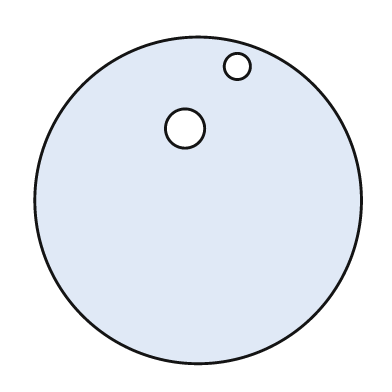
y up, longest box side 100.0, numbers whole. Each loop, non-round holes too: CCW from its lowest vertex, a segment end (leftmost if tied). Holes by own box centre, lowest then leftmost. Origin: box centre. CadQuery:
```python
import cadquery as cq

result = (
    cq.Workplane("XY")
    .moveTo(0.0, 0.0)
    .circle(50.0)
    .moveTo(-4.0, 22.0)
    .circle(6.0)
    .moveTo(12.0, 41.0)
    .circle(4.0)
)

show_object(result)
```